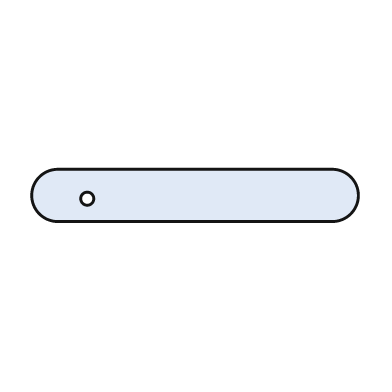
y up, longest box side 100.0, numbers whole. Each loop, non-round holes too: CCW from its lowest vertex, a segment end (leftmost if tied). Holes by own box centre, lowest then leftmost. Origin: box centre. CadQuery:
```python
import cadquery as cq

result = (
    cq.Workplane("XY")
    .moveTo(-42.0, -8.0)
    .lineTo(42.0, -8.0)
    .threePointArc((50.0, 0.0), (42.0, 8.0))
    .lineTo(-42.0, 8.0)
    .threePointArc((-50.0, 0.0), (-42.0, -8.0))
    .close()
    .moveTo(-33.0, -1.0)
    .circle(2.0)
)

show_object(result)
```